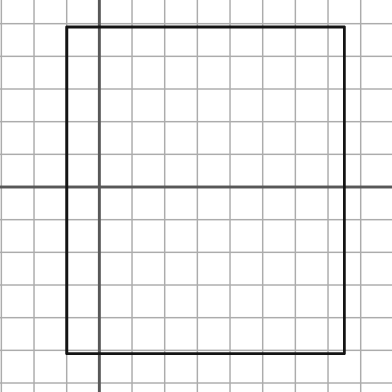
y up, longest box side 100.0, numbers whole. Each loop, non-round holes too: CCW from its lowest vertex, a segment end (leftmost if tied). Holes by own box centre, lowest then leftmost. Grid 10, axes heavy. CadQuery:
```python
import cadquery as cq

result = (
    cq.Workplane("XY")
    .moveTo(-10.0, -51.0)
    .lineTo(75.0, -51.0)
    .lineTo(75.0, 49.0)
    .lineTo(-10.0, 49.0)
    .close()
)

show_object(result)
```